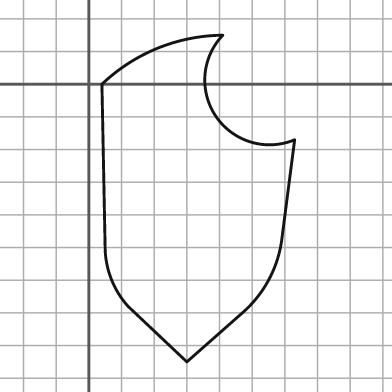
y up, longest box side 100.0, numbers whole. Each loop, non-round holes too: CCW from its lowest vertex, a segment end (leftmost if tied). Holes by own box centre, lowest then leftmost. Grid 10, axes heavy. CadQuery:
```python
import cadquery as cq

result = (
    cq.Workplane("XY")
    .moveTo(30.0, -85.0)
    .lineTo(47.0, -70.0)
    .threePointArc((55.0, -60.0), (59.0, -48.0))
    .lineTo(63.0, -17.0)
    .threePointArc((39.0, -10.0), (41.0, 15.0))
    .threePointArc((21.0, 11.0), (4.0, 0.0))
    .lineTo(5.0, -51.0)
    .threePointArc((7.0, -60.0), (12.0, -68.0))
    .close()
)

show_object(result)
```